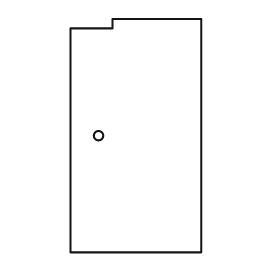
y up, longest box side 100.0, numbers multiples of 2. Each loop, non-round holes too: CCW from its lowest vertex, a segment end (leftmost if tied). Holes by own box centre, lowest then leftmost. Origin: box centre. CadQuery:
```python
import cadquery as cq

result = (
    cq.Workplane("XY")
    .moveTo(-28.0, -50.0)
    .lineTo(28.0, -50.0)
    .lineTo(28.0, 50.0)
    .lineTo(-10.0, 50.0)
    .lineTo(-10.0, 46.0)
    .lineTo(-28.0, 46.0)
    .close()
    .moveTo(-16.0, 0.0)
    .circle(2.0)
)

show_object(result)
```